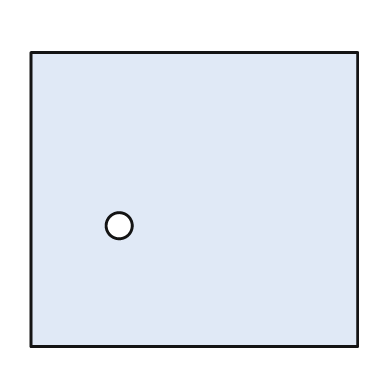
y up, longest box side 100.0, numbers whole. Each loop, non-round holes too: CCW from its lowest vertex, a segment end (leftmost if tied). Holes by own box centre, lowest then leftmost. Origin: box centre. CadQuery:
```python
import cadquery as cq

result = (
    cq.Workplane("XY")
    .moveTo(-50.0, -45.0)
    .lineTo(50.0, -45.0)
    .lineTo(50.0, 45.0)
    .lineTo(-50.0, 45.0)
    .close()
    .moveTo(-23.0, -8.0)
    .circle(4.0)
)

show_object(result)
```